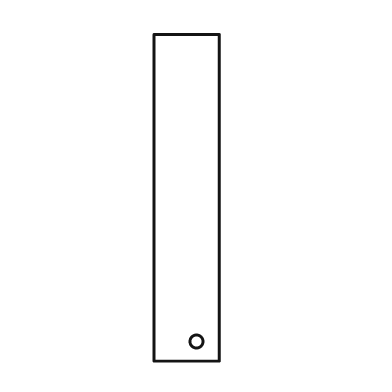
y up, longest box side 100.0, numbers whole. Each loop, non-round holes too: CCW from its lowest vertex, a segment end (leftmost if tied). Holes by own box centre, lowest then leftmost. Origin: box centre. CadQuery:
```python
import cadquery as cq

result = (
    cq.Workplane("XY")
    .moveTo(-10.0, -50.0)
    .lineTo(10.0, -50.0)
    .lineTo(10.0, 50.0)
    .lineTo(-10.0, 50.0)
    .close()
    .moveTo(3.0, -44.0)
    .circle(2.0)
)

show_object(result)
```